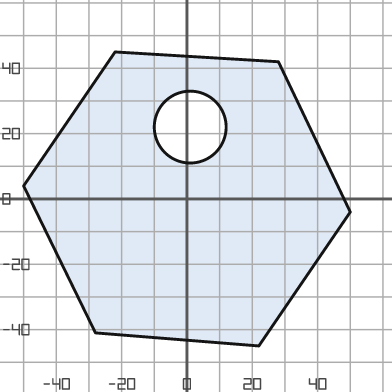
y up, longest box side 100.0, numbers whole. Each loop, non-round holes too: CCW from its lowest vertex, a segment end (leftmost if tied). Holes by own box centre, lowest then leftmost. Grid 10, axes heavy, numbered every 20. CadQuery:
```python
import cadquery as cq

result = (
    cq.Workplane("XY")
    .moveTo(22.0, -45.0)
    .lineTo(50.0, -4.0)
    .lineTo(28.0, 42.0)
    .lineTo(-22.0, 45.0)
    .lineTo(-50.0, 4.0)
    .lineTo(-28.0, -41.0)
    .close()
    .moveTo(1.0, 22.0)
    .circle(11.0)
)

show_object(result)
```